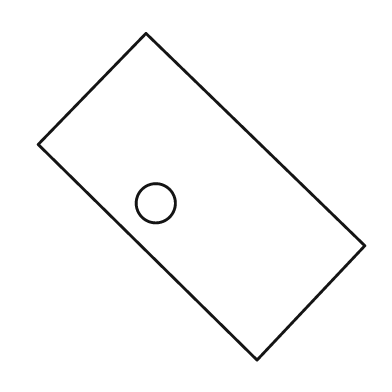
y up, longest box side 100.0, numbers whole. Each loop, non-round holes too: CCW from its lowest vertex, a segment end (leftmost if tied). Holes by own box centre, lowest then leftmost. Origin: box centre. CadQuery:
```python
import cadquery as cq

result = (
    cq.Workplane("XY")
    .moveTo(17.0, -50.0)
    .lineTo(50.0, -15.0)
    .lineTo(-17.0, 50.0)
    .lineTo(-50.0, 16.0)
    .close()
    .moveTo(-14.0, -2.0)
    .circle(6.0)
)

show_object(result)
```